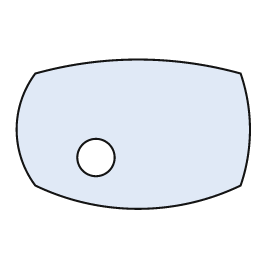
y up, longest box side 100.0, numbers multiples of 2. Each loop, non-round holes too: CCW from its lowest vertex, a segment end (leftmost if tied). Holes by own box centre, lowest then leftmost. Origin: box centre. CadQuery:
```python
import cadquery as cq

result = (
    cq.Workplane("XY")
    .moveTo(-42.0, -22.0)
    .threePointArc((2.0, -32.0), (46.0, -22.0))
    .threePointArc((50.0, 2.0), (46.0, 26.0))
    .threePointArc((2.0, 32.0), (-42.0, 26.0))
    .threePointArc((-50.0, 2.0), (-42.0, -22.0))
    .close()
    .moveTo(-16.0, -10.0)
    .circle(8.0)
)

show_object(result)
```